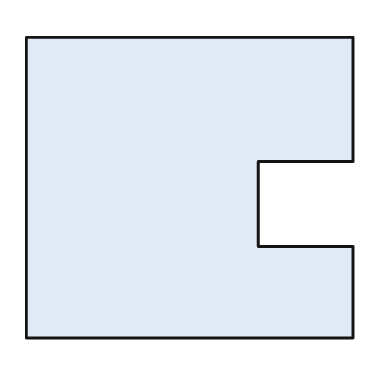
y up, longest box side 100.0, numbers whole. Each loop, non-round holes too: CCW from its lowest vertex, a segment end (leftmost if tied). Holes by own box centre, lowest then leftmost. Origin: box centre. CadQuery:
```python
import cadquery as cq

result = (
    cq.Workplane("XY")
    .moveTo(-50.0, -46.0)
    .lineTo(50.0, -46.0)
    .lineTo(50.0, -18.0)
    .lineTo(21.0, -18.0)
    .lineTo(21.0, 8.0)
    .lineTo(50.0, 8.0)
    .lineTo(50.0, 46.0)
    .lineTo(-50.0, 46.0)
    .close()
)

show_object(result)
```